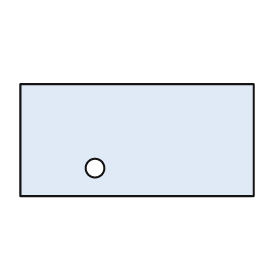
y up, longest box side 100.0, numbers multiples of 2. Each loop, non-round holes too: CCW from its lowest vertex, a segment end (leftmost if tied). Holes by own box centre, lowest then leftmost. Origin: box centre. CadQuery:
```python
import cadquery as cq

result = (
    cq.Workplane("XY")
    .moveTo(-50.0, -24.0)
    .lineTo(50.0, -24.0)
    .lineTo(50.0, 24.0)
    .lineTo(-50.0, 24.0)
    .close()
    .moveTo(-18.0, -12.0)
    .circle(4.0)
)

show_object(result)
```